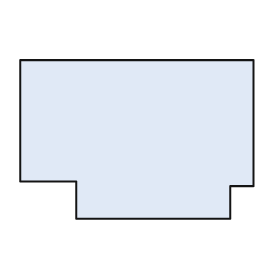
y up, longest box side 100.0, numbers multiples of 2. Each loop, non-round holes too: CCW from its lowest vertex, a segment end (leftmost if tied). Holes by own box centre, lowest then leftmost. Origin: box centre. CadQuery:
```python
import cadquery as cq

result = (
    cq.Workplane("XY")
    .moveTo(-26.0, -34.0)
    .lineTo(40.0, -34.0)
    .lineTo(40.0, -20.0)
    .lineTo(50.0, -20.0)
    .lineTo(50.0, 34.0)
    .lineTo(-50.0, 34.0)
    .lineTo(-50.0, -18.0)
    .lineTo(-26.0, -18.0)
    .close()
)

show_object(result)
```